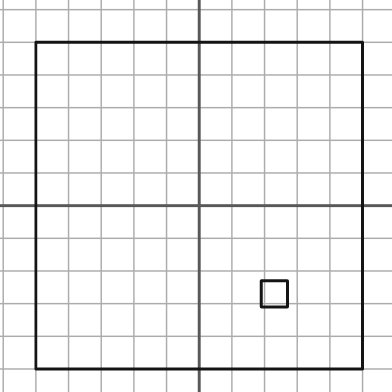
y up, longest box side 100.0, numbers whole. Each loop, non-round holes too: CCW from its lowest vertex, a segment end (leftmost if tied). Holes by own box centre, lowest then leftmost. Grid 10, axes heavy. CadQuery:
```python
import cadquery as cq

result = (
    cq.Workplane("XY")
    .moveTo(-50.0, -50.0)
    .lineTo(50.0, -50.0)
    .lineTo(50.0, 50.0)
    .lineTo(-50.0, 50.0)
    .close()
    .moveTo(19.0, -31.0)
    .lineTo(27.0, -31.0)
    .lineTo(27.0, -23.0)
    .lineTo(19.0, -23.0)
    .close()
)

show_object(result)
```